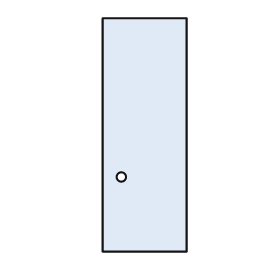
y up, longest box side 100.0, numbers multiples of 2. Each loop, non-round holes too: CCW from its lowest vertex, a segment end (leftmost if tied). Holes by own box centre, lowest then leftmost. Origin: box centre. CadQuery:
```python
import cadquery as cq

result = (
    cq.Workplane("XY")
    .moveTo(-18.0, -50.0)
    .lineTo(18.0, -50.0)
    .lineTo(18.0, 50.0)
    .lineTo(-18.0, 50.0)
    .close()
    .moveTo(-10.0, -18.0)
    .circle(2.0)
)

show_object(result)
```